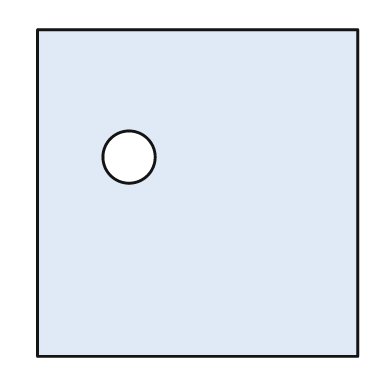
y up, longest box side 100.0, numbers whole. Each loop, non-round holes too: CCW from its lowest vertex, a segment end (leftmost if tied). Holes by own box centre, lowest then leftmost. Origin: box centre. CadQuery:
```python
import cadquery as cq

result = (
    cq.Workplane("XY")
    .moveTo(-49.0, -50.0)
    .lineTo(49.0, -50.0)
    .lineTo(49.0, 50.0)
    .lineTo(-49.0, 50.0)
    .close()
    .moveTo(-21.0, 11.0)
    .circle(8.0)
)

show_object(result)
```